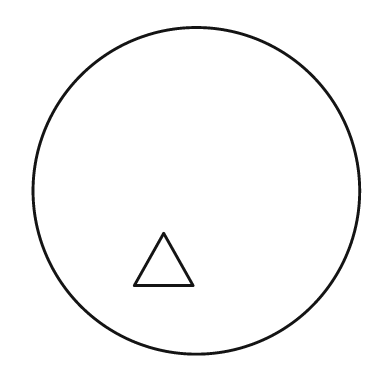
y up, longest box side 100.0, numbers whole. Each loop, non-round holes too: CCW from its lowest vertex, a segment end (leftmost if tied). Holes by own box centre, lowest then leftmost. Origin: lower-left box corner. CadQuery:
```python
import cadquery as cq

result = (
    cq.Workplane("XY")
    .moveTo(50.0, 50.0)
    .circle(50.0)
    .moveTo(31.0, 21.0)
    .lineTo(49.0, 21.0)
    .lineTo(40.0, 37.0)
    .close()
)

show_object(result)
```